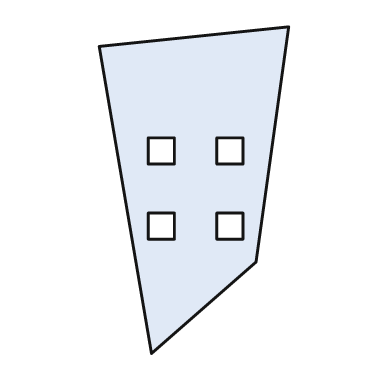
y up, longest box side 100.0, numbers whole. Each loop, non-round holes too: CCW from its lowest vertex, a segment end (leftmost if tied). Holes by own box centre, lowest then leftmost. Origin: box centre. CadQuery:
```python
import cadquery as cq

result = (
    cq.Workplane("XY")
    .moveTo(-13.0, -50.0)
    .lineTo(19.0, -22.0)
    .lineTo(29.0, 50.0)
    .lineTo(-29.0, 44.0)
    .close()
    .moveTo(-14.0, -15.0)
    .lineTo(-6.0, -15.0)
    .lineTo(-6.0, -7.0)
    .lineTo(-14.0, -7.0)
    .close()
    .moveTo(7.0, -15.0)
    .lineTo(15.0, -15.0)
    .lineTo(15.0, -7.0)
    .lineTo(7.0, -7.0)
    .close()
    .moveTo(-14.0, 8.0)
    .lineTo(-6.0, 8.0)
    .lineTo(-6.0, 16.0)
    .lineTo(-14.0, 16.0)
    .close()
    .moveTo(7.0, 8.0)
    .lineTo(15.0, 8.0)
    .lineTo(15.0, 16.0)
    .lineTo(7.0, 16.0)
    .close()
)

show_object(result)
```